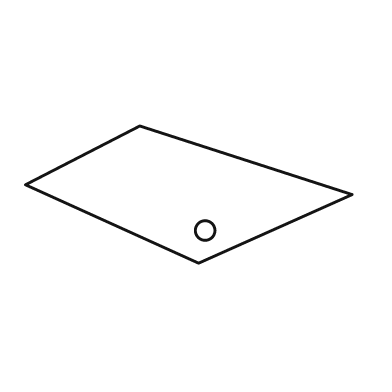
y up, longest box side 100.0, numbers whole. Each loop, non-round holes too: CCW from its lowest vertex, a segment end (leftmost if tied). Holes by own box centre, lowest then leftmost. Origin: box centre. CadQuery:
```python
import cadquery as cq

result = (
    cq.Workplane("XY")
    .moveTo(3.0, -21.0)
    .lineTo(50.0, 0.0)
    .lineTo(-15.0, 21.0)
    .lineTo(-50.0, 3.0)
    .close()
    .moveTo(5.0, -11.0)
    .circle(3.0)
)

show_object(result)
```